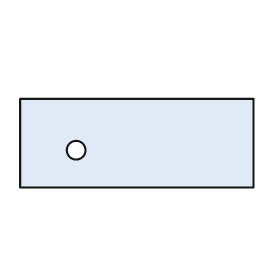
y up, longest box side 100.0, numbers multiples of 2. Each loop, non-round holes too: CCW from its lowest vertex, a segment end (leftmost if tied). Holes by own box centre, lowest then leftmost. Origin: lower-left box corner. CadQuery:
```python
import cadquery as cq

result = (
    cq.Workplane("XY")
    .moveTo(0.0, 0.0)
    .lineTo(100.0, 0.0)
    .lineTo(100.0, 38.0)
    .lineTo(0.0, 38.0)
    .close()
    .moveTo(24.0, 16.0)
    .circle(4.0)
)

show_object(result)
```